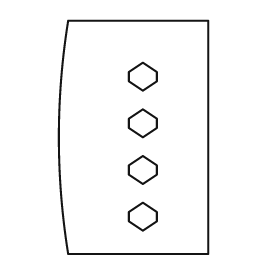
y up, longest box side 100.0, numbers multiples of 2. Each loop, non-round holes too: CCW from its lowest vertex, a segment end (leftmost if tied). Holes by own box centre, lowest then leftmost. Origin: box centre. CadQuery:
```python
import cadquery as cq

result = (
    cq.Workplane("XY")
    .moveTo(-28.0, -50.0)
    .lineTo(32.0, -50.0)
    .lineTo(32.0, 50.0)
    .lineTo(-28.0, 50.0)
    .threePointArc((-32.0, 0.0), (-28.0, -50.0))
    .close()
    .moveTo(4.0, -40.0)
    .lineTo(10.0, -36.0)
    .lineTo(10.0, -32.0)
    .lineTo(4.0, -28.0)
    .lineTo(-2.0, -32.0)
    .lineTo(-2.0, -36.0)
    .close()
    .moveTo(4.0, -20.0)
    .lineTo(10.0, -16.0)
    .lineTo(10.0, -12.0)
    .lineTo(4.0, -8.0)
    .lineTo(-2.0, -12.0)
    .lineTo(-2.0, -16.0)
    .close()
    .moveTo(4.0, 0.0)
    .lineTo(10.0, 4.0)
    .lineTo(10.0, 8.0)
    .lineTo(4.0, 12.0)
    .lineTo(-2.0, 8.0)
    .lineTo(-2.0, 4.0)
    .close()
    .moveTo(4.0, 20.0)
    .lineTo(10.0, 24.0)
    .lineTo(10.0, 28.0)
    .lineTo(4.0, 32.0)
    .lineTo(-2.0, 28.0)
    .lineTo(-2.0, 24.0)
    .close()
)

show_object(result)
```